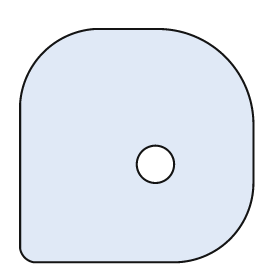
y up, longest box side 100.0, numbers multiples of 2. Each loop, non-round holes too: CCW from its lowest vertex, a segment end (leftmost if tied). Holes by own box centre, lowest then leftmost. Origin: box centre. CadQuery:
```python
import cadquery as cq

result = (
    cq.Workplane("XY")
    .moveTo(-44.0, -50.0)
    .lineTo(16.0, -50.0)
    .threePointArc((40.0, -40.0), (50.0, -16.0))
    .lineTo(50.0, 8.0)
    .threePointArc((38.0, 38.0), (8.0, 50.0))
    .lineTo(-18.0, 50.0)
    .threePointArc((-40.0, 40.0), (-50.0, 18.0))
    .lineTo(-50.0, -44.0)
    .threePointArc((-48.0, -48.0), (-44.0, -50.0))
    .close()
    .moveTo(8.0, -8.0)
    .circle(8.0)
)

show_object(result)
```